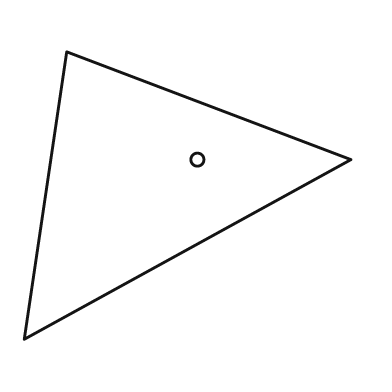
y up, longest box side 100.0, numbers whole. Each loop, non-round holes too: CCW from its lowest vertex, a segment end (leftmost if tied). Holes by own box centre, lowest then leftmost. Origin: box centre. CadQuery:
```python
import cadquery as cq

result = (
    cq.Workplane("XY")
    .moveTo(-50.0, -44.0)
    .lineTo(50.0, 11.0)
    .lineTo(-37.0, 44.0)
    .close()
    .moveTo(3.0, 11.0)
    .circle(2.0)
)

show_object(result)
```